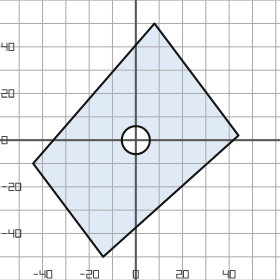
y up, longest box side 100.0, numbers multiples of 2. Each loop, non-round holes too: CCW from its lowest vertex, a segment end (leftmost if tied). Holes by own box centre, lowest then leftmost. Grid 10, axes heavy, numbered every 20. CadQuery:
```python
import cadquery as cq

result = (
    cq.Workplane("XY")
    .moveTo(-14.0, -50.0)
    .lineTo(44.0, 2.0)
    .lineTo(8.0, 50.0)
    .lineTo(-44.0, -10.0)
    .close()
    .moveTo(0.0, 0.0)
    .circle(6.0)
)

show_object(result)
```